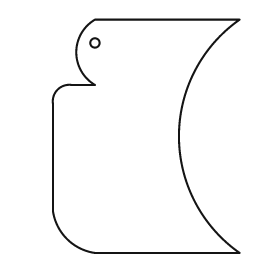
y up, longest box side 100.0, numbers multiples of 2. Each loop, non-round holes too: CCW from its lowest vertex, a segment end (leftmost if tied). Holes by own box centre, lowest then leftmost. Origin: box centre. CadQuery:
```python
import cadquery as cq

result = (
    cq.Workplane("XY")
    .moveTo(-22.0, -50.0)
    .lineTo(40.0, -50.0)
    .threePointArc((14.0, 0.0), (40.0, 50.0))
    .lineTo(-22.0, 50.0)
    .threePointArc((-30.0, 36.0), (-22.0, 22.0))
    .lineTo(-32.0, 22.0)
    .threePointArc((-38.0, 20.0), (-40.0, 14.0))
    .lineTo(-40.0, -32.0)
    .threePointArc((-34.0, -44.0), (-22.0, -50.0))
    .close()
    .moveTo(-22.0, 40.0)
    .circle(2.0)
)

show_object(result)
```